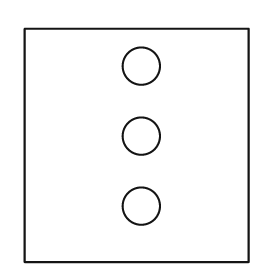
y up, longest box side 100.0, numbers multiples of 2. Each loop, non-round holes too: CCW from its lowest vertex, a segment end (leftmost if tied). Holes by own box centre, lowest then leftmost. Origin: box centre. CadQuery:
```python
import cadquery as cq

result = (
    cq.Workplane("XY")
    .moveTo(-48.0, -50.0)
    .lineTo(48.0, -50.0)
    .lineTo(48.0, 50.0)
    .lineTo(-48.0, 50.0)
    .close()
    .moveTo(2.0, -26.0)
    .circle(8.0)
    .moveTo(2.0, 4.0)
    .circle(8.0)
    .moveTo(2.0, 34.0)
    .circle(8.0)
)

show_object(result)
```